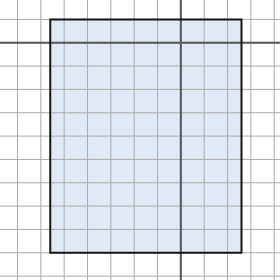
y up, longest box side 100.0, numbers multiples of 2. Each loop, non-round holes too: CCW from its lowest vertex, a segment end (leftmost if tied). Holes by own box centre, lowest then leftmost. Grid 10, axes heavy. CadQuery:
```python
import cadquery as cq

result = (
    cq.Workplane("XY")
    .moveTo(-56.0, -90.0)
    .lineTo(26.0, -90.0)
    .lineTo(26.0, 10.0)
    .lineTo(-56.0, 10.0)
    .close()
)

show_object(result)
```